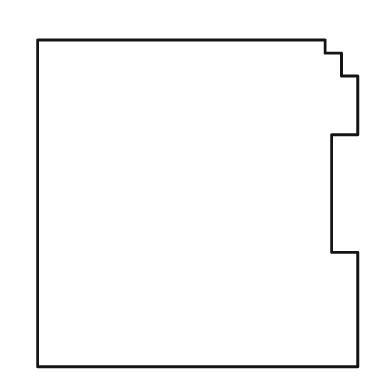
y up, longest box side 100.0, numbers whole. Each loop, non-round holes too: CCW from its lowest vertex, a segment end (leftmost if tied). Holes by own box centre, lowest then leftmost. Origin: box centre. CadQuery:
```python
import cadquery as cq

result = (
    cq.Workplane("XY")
    .moveTo(-49.0, -50.0)
    .lineTo(49.0, -50.0)
    .lineTo(49.0, -15.0)
    .lineTo(41.0, -15.0)
    .lineTo(41.0, 21.0)
    .lineTo(49.0, 21.0)
    .lineTo(49.0, 39.0)
    .lineTo(44.0, 39.0)
    .lineTo(44.0, 46.0)
    .lineTo(39.0, 46.0)
    .lineTo(39.0, 50.0)
    .lineTo(-49.0, 50.0)
    .close()
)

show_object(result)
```